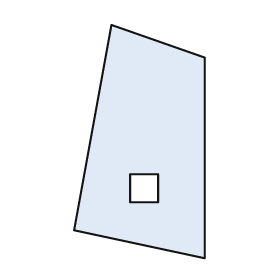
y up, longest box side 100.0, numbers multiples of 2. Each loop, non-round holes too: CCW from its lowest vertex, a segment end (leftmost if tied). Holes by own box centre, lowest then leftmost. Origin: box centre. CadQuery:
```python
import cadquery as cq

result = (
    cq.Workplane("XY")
    .moveTo(28.0, -50.0)
    .lineTo(28.0, 36.0)
    .lineTo(-12.0, 50.0)
    .lineTo(-28.0, -38.0)
    .close()
    .moveTo(-4.0, -26.0)
    .lineTo(8.0, -26.0)
    .lineTo(8.0, -14.0)
    .lineTo(-4.0, -14.0)
    .close()
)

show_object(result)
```